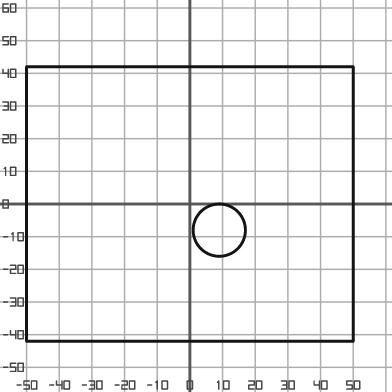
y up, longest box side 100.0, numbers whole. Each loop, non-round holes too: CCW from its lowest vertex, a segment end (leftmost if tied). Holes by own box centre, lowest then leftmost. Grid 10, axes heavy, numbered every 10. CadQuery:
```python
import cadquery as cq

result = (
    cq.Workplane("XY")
    .moveTo(-50.0, -42.0)
    .lineTo(50.0, -42.0)
    .lineTo(50.0, 42.0)
    .lineTo(-50.0, 42.0)
    .close()
    .moveTo(9.0, -8.0)
    .circle(8.0)
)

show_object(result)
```